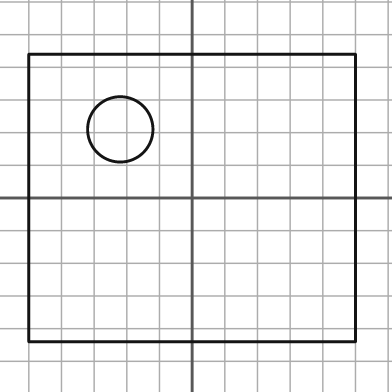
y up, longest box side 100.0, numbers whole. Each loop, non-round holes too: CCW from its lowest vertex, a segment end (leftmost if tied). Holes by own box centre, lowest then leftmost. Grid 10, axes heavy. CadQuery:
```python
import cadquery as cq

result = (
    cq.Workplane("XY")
    .moveTo(-50.0, -44.0)
    .lineTo(50.0, -44.0)
    .lineTo(50.0, 44.0)
    .lineTo(-50.0, 44.0)
    .close()
    .moveTo(-22.0, 21.0)
    .circle(10.0)
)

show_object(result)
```